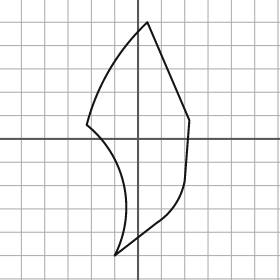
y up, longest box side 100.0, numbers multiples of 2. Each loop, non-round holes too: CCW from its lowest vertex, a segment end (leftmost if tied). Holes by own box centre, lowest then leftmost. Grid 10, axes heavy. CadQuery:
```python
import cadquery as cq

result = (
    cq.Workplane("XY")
    .moveTo(-10.0, -50.0)
    .lineTo(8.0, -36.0)
    .threePointArc((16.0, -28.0), (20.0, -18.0))
    .lineTo(22.0, 8.0)
    .lineTo(4.0, 50.0)
    .threePointArc((-12.0, 30.0), (-22.0, 6.0))
    .threePointArc((-6.0, -20.0), (-10.0, -50.0))
    .close()
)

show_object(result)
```